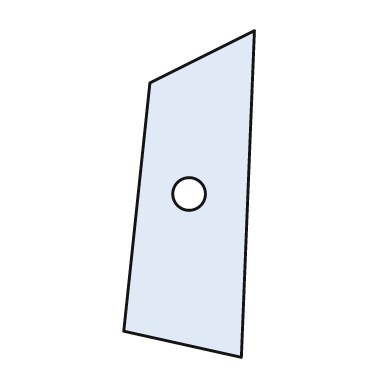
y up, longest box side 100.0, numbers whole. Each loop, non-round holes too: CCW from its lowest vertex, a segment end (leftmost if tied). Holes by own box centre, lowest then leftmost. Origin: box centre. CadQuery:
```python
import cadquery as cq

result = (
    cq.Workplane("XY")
    .moveTo(16.0, -50.0)
    .lineTo(20.0, 50.0)
    .lineTo(-12.0, 34.0)
    .lineTo(-20.0, -42.0)
    .close()
    .moveTo(0.0, 0.0)
    .circle(5.0)
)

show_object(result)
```